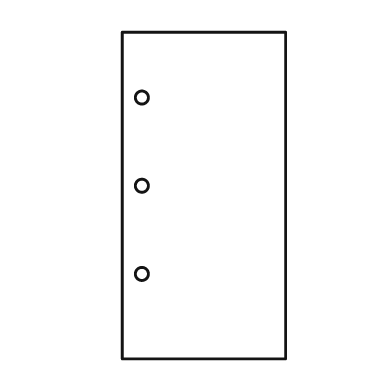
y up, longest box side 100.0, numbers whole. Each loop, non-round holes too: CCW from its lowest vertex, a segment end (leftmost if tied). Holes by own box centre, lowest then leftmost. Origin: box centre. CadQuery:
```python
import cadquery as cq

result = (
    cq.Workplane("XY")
    .moveTo(-25.0, -50.0)
    .lineTo(25.0, -50.0)
    .lineTo(25.0, 50.0)
    .lineTo(-25.0, 50.0)
    .close()
    .moveTo(-19.0, -24.0)
    .circle(2.0)
    .moveTo(-19.0, 3.0)
    .circle(2.0)
    .moveTo(-19.0, 30.0)
    .circle(2.0)
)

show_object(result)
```